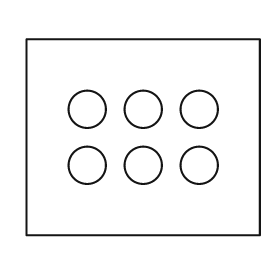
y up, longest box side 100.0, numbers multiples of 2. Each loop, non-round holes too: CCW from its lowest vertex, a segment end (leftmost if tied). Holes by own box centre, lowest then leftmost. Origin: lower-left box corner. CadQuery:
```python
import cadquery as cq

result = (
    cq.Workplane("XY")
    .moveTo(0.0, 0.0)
    .lineTo(100.0, 0.0)
    .lineTo(100.0, 84.0)
    .lineTo(0.0, 84.0)
    .close()
    .moveTo(26.0, 30.0)
    .circle(8.0)
    .moveTo(50.0, 30.0)
    .circle(8.0)
    .moveTo(74.0, 30.0)
    .circle(8.0)
    .moveTo(26.0, 54.0)
    .circle(8.0)
    .moveTo(50.0, 54.0)
    .circle(8.0)
    .moveTo(74.0, 54.0)
    .circle(8.0)
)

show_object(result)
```